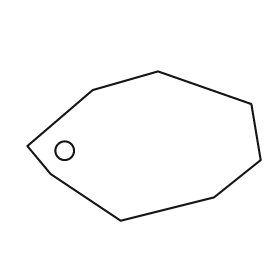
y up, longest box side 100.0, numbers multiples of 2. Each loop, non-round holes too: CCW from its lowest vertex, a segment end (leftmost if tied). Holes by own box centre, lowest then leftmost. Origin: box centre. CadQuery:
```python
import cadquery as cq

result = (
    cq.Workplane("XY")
    .moveTo(-10.0, -32.0)
    .lineTo(30.0, -22.0)
    .lineTo(50.0, -6.0)
    .lineTo(46.0, 18.0)
    .lineTo(6.0, 32.0)
    .lineTo(-22.0, 24.0)
    .lineTo(-50.0, 0.0)
    .lineTo(-40.0, -12.0)
    .close()
    .moveTo(-34.0, -2.0)
    .circle(4.0)
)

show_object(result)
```